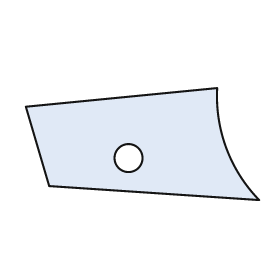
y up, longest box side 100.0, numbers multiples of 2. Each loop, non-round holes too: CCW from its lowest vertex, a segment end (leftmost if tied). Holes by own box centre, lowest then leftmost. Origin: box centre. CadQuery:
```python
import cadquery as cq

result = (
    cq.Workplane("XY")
    .moveTo(50.0, -24.0)
    .threePointArc((36.0, -2.0), (32.0, 24.0))
    .lineTo(-50.0, 16.0)
    .lineTo(-40.0, -18.0)
    .close()
    .moveTo(-6.0, -6.0)
    .circle(6.0)
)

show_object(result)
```